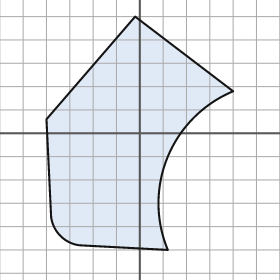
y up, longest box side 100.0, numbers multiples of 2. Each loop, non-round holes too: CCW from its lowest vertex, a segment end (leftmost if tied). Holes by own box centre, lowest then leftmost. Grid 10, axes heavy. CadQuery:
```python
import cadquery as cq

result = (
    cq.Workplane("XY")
    .moveTo(12.0, -50.0)
    .threePointArc((12.0, -10.0), (40.0, 18.0))
    .lineTo(-2.0, 50.0)
    .lineTo(-40.0, 6.0)
    .lineTo(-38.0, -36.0)
    .threePointArc((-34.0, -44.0), (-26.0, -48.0))
    .close()
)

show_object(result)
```